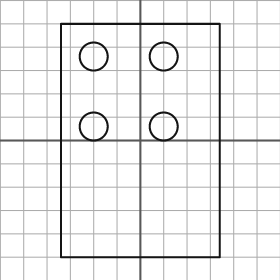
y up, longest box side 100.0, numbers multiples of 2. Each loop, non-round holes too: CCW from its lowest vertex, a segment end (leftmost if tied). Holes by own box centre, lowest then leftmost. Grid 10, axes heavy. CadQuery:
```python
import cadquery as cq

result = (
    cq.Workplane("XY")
    .moveTo(-34.0, -50.0)
    .lineTo(34.0, -50.0)
    .lineTo(34.0, 50.0)
    .lineTo(-34.0, 50.0)
    .close()
    .moveTo(-20.0, 6.0)
    .circle(6.0)
    .moveTo(10.0, 6.0)
    .circle(6.0)
    .moveTo(-20.0, 36.0)
    .circle(6.0)
    .moveTo(10.0, 36.0)
    .circle(6.0)
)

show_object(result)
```